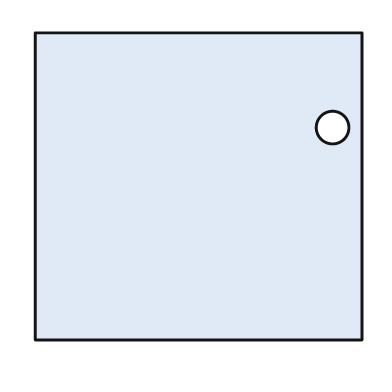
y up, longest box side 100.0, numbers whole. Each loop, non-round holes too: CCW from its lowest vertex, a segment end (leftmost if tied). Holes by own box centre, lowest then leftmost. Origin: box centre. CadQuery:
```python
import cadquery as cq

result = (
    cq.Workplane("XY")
    .moveTo(-50.0, -47.0)
    .lineTo(50.0, -47.0)
    .lineTo(50.0, 47.0)
    .lineTo(-50.0, 47.0)
    .close()
    .moveTo(41.0, 18.0)
    .circle(5.0)
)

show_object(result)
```